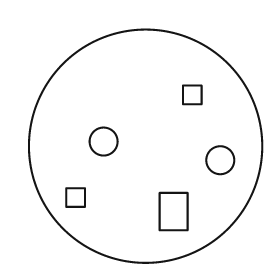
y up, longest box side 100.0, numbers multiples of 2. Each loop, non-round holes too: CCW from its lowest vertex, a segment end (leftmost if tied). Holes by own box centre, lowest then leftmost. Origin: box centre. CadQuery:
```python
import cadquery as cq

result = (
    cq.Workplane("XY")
    .moveTo(0.0, 0.0)
    .circle(50.0)
    .moveTo(6.0, -36.0)
    .lineTo(18.0, -36.0)
    .lineTo(18.0, -20.0)
    .lineTo(6.0, -20.0)
    .close()
    .moveTo(-34.0, -26.0)
    .lineTo(-26.0, -26.0)
    .lineTo(-26.0, -18.0)
    .lineTo(-34.0, -18.0)
    .close()
    .moveTo(32.0, -6.0)
    .circle(6.0)
    .moveTo(-18.0, 2.0)
    .circle(6.0)
    .moveTo(16.0, 18.0)
    .lineTo(24.0, 18.0)
    .lineTo(24.0, 26.0)
    .lineTo(16.0, 26.0)
    .close()
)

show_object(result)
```